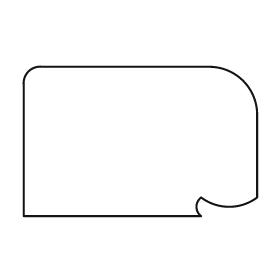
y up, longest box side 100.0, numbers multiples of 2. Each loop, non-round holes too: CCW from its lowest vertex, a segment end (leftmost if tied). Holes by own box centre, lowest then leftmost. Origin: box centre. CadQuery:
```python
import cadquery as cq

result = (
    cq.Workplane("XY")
    .moveTo(-50.0, -32.0)
    .lineTo(26.0, -32.0)
    .threePointArc((24.0, -28.0), (26.0, -24.0))
    .threePointArc((38.0, -28.0), (50.0, -24.0))
    .lineTo(50.0, 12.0)
    .threePointArc((44.0, 26.0), (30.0, 32.0))
    .lineTo(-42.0, 32.0)
    .threePointArc((-48.0, 30.0), (-50.0, 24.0))
    .close()
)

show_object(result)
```